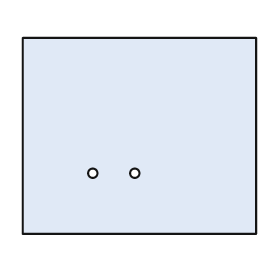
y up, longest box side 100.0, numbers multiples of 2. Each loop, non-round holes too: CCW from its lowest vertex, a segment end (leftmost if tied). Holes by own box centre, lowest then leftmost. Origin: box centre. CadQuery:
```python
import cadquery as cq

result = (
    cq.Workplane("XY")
    .moveTo(-50.0, -42.0)
    .lineTo(50.0, -42.0)
    .lineTo(50.0, 42.0)
    .lineTo(-50.0, 42.0)
    .close()
    .moveTo(-20.0, -16.0)
    .circle(2.0)
    .moveTo(-2.0, -16.0)
    .circle(2.0)
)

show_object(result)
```